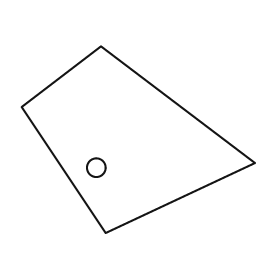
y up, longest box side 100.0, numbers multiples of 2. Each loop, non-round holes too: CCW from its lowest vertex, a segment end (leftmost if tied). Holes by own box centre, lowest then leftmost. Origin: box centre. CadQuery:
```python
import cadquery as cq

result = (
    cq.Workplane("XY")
    .moveTo(-14.0, -40.0)
    .lineTo(50.0, -10.0)
    .lineTo(-16.0, 40.0)
    .lineTo(-50.0, 14.0)
    .close()
    .moveTo(-18.0, -12.0)
    .circle(4.0)
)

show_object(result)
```